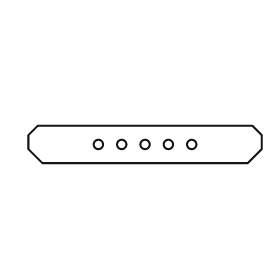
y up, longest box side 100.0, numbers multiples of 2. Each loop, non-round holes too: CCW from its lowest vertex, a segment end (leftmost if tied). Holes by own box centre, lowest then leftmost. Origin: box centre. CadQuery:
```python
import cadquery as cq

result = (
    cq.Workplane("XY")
    .moveTo(-44.0, -8.0)
    .lineTo(44.0, -8.0)
    .lineTo(50.0, -2.0)
    .lineTo(50.0, 4.0)
    .lineTo(46.0, 8.0)
    .lineTo(-46.0, 8.0)
    .lineTo(-50.0, 4.0)
    .lineTo(-50.0, -2.0)
    .close()
    .moveTo(-20.0, 0.0)
    .circle(2.0)
    .moveTo(-10.0, 0.0)
    .circle(2.0)
    .moveTo(0.0, 0.0)
    .circle(2.0)
    .moveTo(10.0, 0.0)
    .circle(2.0)
    .moveTo(20.0, 0.0)
    .circle(2.0)
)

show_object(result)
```